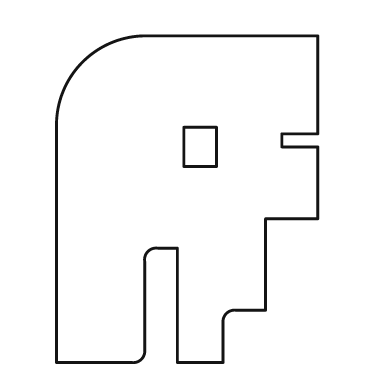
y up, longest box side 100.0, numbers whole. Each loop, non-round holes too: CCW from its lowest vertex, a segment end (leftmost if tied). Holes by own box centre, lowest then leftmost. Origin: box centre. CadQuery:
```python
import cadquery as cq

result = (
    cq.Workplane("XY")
    .moveTo(-40.0, -50.0)
    .lineTo(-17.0, -50.0)
    .threePointArc((-14.0, -49.0), (-13.0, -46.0))
    .lineTo(-13.0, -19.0)
    .threePointArc((-12.0, -16.0), (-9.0, -15.0))
    .lineTo(-3.0, -15.0)
    .lineTo(-3.0, -50.0)
    .lineTo(11.0, -50.0)
    .lineTo(11.0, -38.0)
    .threePointArc((12.0, -35.0), (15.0, -34.0))
    .lineTo(24.0, -34.0)
    .lineTo(24.0, -6.0)
    .lineTo(40.0, -6.0)
    .lineTo(40.0, 16.0)
    .lineTo(29.0, 16.0)
    .lineTo(29.0, 20.0)
    .lineTo(40.0, 20.0)
    .lineTo(40.0, 50.0)
    .lineTo(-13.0, 50.0)
    .threePointArc((-32.0, 42.0), (-40.0, 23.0))
    .close()
    .moveTo(-1.0, 10.0)
    .lineTo(9.0, 10.0)
    .lineTo(9.0, 22.0)
    .lineTo(-1.0, 22.0)
    .close()
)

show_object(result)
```